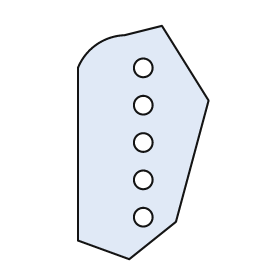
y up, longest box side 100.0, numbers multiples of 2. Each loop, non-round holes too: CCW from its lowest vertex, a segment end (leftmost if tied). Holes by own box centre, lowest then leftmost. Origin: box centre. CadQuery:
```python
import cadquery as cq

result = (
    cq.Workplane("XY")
    .moveTo(-6.0, -50.0)
    .lineTo(14.0, -34.0)
    .lineTo(28.0, 18.0)
    .lineTo(8.0, 50.0)
    .lineTo(-8.0, 46.0)
    .threePointArc((-20.0, 42.0), (-28.0, 32.0))
    .lineTo(-28.0, -42.0)
    .close()
    .moveTo(0.0, -32.0)
    .circle(4.0)
    .moveTo(0.0, -16.0)
    .circle(4.0)
    .moveTo(0.0, 0.0)
    .circle(4.0)
    .moveTo(0.0, 16.0)
    .circle(4.0)
    .moveTo(0.0, 32.0)
    .circle(4.0)
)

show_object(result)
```